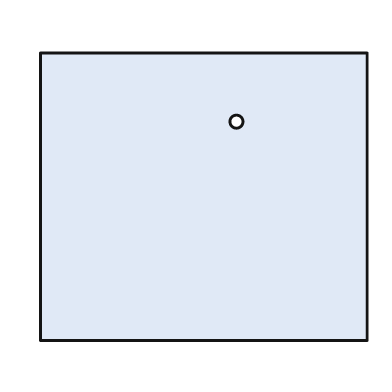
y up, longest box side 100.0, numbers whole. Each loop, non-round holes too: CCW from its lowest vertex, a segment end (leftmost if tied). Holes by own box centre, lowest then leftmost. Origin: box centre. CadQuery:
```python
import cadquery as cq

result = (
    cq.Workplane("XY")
    .moveTo(-50.0, -44.0)
    .lineTo(50.0, -44.0)
    .lineTo(50.0, 44.0)
    .lineTo(-50.0, 44.0)
    .close()
    .moveTo(10.0, 23.0)
    .circle(2.0)
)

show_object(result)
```